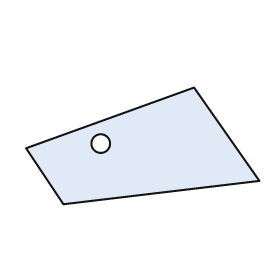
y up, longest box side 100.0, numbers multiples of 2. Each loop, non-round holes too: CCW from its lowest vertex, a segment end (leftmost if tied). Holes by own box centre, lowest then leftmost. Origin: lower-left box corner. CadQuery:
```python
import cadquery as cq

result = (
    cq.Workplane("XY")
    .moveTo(16.0, 0.0)
    .lineTo(100.0, 10.0)
    .lineTo(72.0, 50.0)
    .lineTo(0.0, 24.0)
    .close()
    .moveTo(32.0, 26.0)
    .circle(4.0)
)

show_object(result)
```